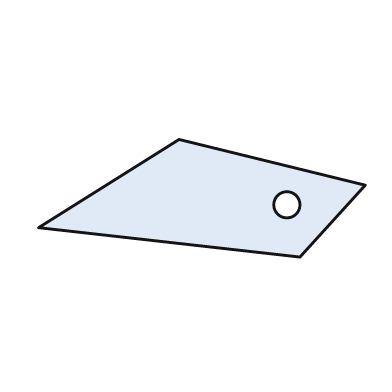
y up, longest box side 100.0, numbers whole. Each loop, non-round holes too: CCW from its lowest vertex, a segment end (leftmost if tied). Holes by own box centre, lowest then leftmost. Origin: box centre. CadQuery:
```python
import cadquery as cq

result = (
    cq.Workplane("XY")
    .moveTo(30.0, -18.0)
    .lineTo(50.0, 4.0)
    .lineTo(-7.0, 18.0)
    .lineTo(-50.0, -9.0)
    .close()
    .moveTo(26.0, -2.0)
    .circle(4.0)
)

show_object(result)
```